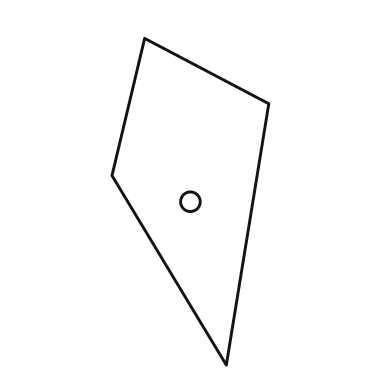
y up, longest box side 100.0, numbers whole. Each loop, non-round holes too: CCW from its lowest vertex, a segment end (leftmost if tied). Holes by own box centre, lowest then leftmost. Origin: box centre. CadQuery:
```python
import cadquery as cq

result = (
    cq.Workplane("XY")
    .moveTo(11.0, -50.0)
    .lineTo(24.0, 30.0)
    .lineTo(-14.0, 50.0)
    .lineTo(-24.0, 8.0)
    .close()
    .moveTo(0.0, 0.0)
    .circle(3.0)
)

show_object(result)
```